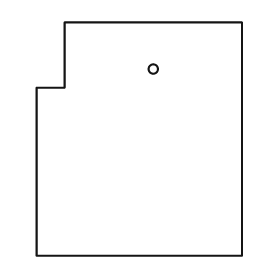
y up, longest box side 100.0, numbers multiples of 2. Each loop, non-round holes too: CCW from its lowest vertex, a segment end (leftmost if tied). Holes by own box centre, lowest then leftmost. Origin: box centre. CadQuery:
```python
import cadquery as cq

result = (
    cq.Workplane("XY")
    .moveTo(-44.0, -50.0)
    .lineTo(44.0, -50.0)
    .lineTo(44.0, 50.0)
    .lineTo(-32.0, 50.0)
    .lineTo(-32.0, 22.0)
    .lineTo(-44.0, 22.0)
    .close()
    .moveTo(6.0, 30.0)
    .circle(2.0)
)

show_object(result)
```